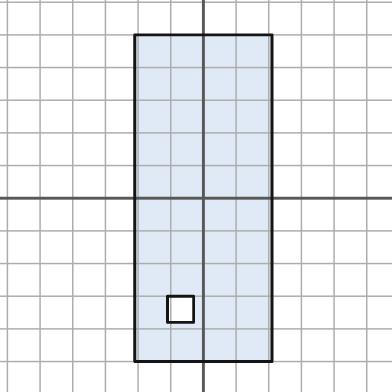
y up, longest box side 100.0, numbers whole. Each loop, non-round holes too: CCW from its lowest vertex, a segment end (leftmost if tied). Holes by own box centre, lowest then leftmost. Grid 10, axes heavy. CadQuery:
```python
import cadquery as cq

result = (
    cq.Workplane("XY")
    .moveTo(-21.0, -50.0)
    .lineTo(21.0, -50.0)
    .lineTo(21.0, 50.0)
    .lineTo(-21.0, 50.0)
    .close()
    .moveTo(-11.0, -38.0)
    .lineTo(-3.0, -38.0)
    .lineTo(-3.0, -30.0)
    .lineTo(-11.0, -30.0)
    .close()
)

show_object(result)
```